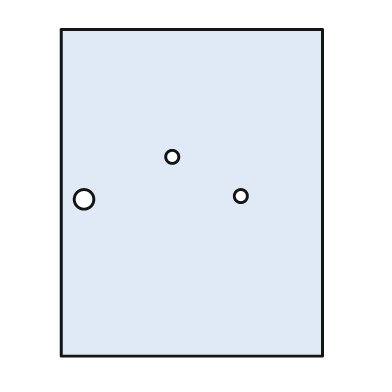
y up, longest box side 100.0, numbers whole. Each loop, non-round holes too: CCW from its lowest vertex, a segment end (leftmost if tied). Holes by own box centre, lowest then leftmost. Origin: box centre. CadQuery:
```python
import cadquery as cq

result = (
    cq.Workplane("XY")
    .moveTo(-40.0, -50.0)
    .lineTo(40.0, -50.0)
    .lineTo(40.0, 50.0)
    .lineTo(-40.0, 50.0)
    .close()
    .moveTo(-33.0, -2.0)
    .circle(3.0)
    .moveTo(15.0, -1.0)
    .circle(2.0)
    .moveTo(-6.0, 11.0)
    .circle(2.0)
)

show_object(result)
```